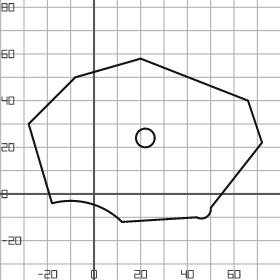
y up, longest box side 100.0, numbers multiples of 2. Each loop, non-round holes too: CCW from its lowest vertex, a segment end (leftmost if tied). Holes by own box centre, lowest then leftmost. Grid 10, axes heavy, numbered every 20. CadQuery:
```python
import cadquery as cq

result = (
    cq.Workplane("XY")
    .moveTo(12.0, -12.0)
    .lineTo(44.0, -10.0)
    .threePointArc((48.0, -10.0), (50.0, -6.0))
    .lineTo(72.0, 22.0)
    .lineTo(66.0, 40.0)
    .lineTo(20.0, 58.0)
    .lineTo(-8.0, 50.0)
    .lineTo(-28.0, 30.0)
    .lineTo(-18.0, -4.0)
    .threePointArc((-2.0, -4.0), (12.0, -12.0))
    .close()
    .moveTo(22.0, 24.0)
    .circle(4.0)
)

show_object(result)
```